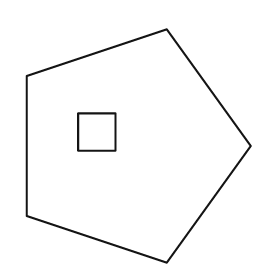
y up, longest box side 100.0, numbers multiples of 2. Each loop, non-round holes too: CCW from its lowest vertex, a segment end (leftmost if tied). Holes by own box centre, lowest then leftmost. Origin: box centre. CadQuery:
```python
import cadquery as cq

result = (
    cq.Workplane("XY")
    .moveTo(12.0, -50.0)
    .lineTo(48.0, 0.0)
    .lineTo(12.0, 50.0)
    .lineTo(-48.0, 30.0)
    .lineTo(-48.0, -30.0)
    .close()
    .moveTo(-26.0, -2.0)
    .lineTo(-10.0, -2.0)
    .lineTo(-10.0, 14.0)
    .lineTo(-26.0, 14.0)
    .close()
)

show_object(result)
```